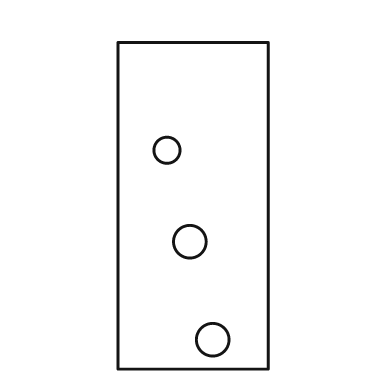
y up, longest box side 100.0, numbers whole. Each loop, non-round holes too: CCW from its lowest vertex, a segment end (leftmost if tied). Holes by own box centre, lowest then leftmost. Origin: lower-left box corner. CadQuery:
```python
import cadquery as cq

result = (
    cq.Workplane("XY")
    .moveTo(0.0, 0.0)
    .lineTo(46.0, 0.0)
    .lineTo(46.0, 100.0)
    .lineTo(0.0, 100.0)
    .close()
    .moveTo(29.0, 9.0)
    .circle(5.0)
    .moveTo(22.0, 39.0)
    .circle(5.0)
    .moveTo(15.0, 67.0)
    .circle(4.0)
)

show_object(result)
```